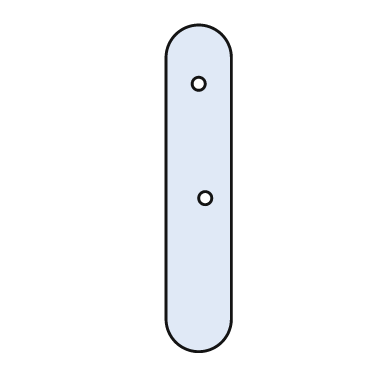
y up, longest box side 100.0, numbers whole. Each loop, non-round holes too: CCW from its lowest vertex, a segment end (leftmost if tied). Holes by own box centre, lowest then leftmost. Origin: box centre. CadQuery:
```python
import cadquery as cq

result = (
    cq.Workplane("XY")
    .moveTo(-10.0, -40.0)
    .threePointArc((0.0, -50.0), (10.0, -40.0))
    .lineTo(10.0, 40.0)
    .threePointArc((0.0, 50.0), (-10.0, 40.0))
    .close()
    .moveTo(2.0, -3.0)
    .circle(2.0)
    .moveTo(0.0, 32.0)
    .circle(2.0)
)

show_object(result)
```